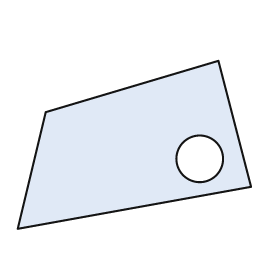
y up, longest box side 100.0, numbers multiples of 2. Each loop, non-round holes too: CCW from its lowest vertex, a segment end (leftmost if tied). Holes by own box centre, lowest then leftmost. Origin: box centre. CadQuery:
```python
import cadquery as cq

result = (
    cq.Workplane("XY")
    .moveTo(-50.0, -36.0)
    .lineTo(50.0, -18.0)
    .lineTo(36.0, 36.0)
    .lineTo(-38.0, 14.0)
    .close()
    .moveTo(28.0, -6.0)
    .circle(10.0)
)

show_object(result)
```